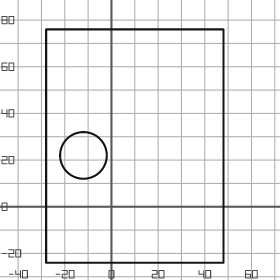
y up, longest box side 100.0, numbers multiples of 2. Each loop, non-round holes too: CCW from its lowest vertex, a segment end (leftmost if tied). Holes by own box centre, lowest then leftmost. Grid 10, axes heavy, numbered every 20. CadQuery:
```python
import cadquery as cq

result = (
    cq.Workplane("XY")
    .moveTo(-28.0, -24.0)
    .lineTo(48.0, -24.0)
    .lineTo(48.0, 76.0)
    .lineTo(-28.0, 76.0)
    .close()
    .moveTo(-12.0, 22.0)
    .circle(10.0)
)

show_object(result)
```